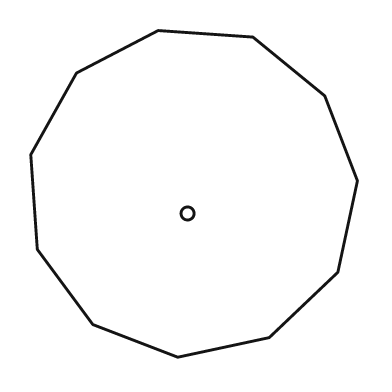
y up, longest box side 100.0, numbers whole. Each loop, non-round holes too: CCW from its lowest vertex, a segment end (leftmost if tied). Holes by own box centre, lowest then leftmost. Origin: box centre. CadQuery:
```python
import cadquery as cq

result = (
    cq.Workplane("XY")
    .moveTo(-5.0, -50.0)
    .lineTo(23.0, -44.0)
    .lineTo(44.0, -24.0)
    .lineTo(50.0, 4.0)
    .lineTo(40.0, 30.0)
    .lineTo(18.0, 48.0)
    .lineTo(-11.0, 50.0)
    .lineTo(-36.0, 37.0)
    .lineTo(-50.0, 12.0)
    .lineTo(-48.0, -17.0)
    .lineTo(-31.0, -40.0)
    .close()
    .moveTo(-2.0, -6.0)
    .circle(2.0)
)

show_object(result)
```